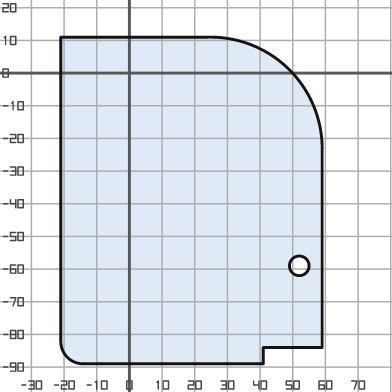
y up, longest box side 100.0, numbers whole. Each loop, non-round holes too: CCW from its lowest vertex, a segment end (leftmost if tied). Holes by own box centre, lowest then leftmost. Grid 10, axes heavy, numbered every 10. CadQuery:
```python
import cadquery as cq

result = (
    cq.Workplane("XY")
    .moveTo(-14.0, -89.0)
    .lineTo(41.0, -89.0)
    .lineTo(41.0, -84.0)
    .lineTo(59.0, -84.0)
    .lineTo(59.0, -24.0)
    .threePointArc((49.0, 1.0), (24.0, 11.0))
    .lineTo(-21.0, 11.0)
    .lineTo(-21.0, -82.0)
    .threePointArc((-19.0, -87.0), (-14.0, -89.0))
    .close()
    .moveTo(52.0, -59.0)
    .circle(3.0)
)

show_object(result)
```